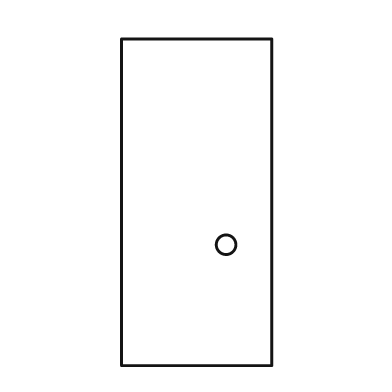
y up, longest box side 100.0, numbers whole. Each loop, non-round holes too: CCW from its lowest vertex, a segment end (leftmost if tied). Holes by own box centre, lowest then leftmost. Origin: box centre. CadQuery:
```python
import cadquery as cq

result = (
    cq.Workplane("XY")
    .moveTo(-23.0, -50.0)
    .lineTo(23.0, -50.0)
    .lineTo(23.0, 50.0)
    .lineTo(-23.0, 50.0)
    .close()
    .moveTo(9.0, -13.0)
    .circle(3.0)
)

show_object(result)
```